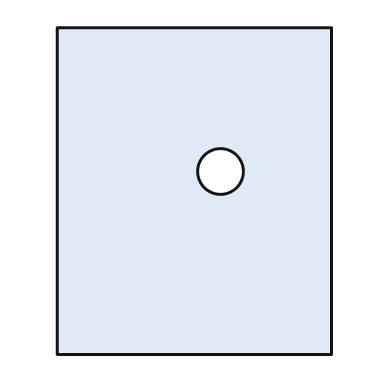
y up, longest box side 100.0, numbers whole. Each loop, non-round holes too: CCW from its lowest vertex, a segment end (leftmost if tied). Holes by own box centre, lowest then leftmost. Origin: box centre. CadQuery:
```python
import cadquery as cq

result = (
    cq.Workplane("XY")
    .moveTo(-42.0, -50.0)
    .lineTo(42.0, -50.0)
    .lineTo(42.0, 50.0)
    .lineTo(-42.0, 50.0)
    .close()
    .moveTo(8.0, 6.0)
    .circle(7.0)
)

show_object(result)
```